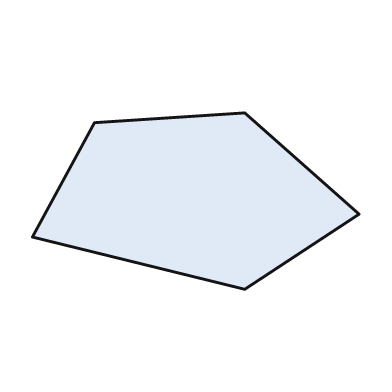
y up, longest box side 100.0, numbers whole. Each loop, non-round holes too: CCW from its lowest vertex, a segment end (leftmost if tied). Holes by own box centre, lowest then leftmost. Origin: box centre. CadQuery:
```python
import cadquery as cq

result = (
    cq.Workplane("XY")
    .moveTo(15.0, -27.0)
    .lineTo(50.0, -4.0)
    .lineTo(15.0, 27.0)
    .lineTo(-31.0, 24.0)
    .lineTo(-50.0, -11.0)
    .close()
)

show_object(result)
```